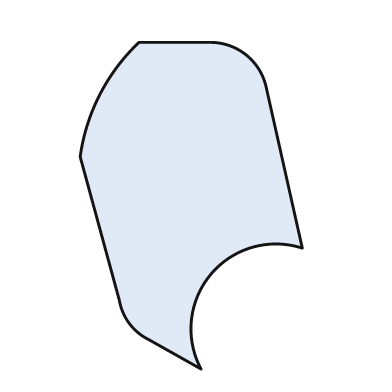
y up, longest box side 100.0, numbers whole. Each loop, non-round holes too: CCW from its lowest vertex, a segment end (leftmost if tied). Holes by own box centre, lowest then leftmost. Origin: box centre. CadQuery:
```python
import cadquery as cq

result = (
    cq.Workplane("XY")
    .moveTo(3.0, -50.0)
    .threePointArc((6.0, -21.0), (34.0, -13.0))
    .lineTo(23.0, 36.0)
    .threePointArc((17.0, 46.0), (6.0, 50.0))
    .lineTo(-16.0, 50.0)
    .threePointArc((-28.0, 34.0), (-34.0, 15.0))
    .lineTo(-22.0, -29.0)
    .threePointArc((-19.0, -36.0), (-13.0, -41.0))
    .close()
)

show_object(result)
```